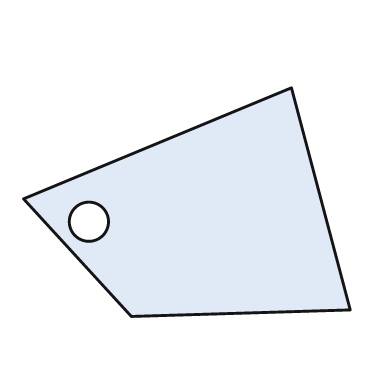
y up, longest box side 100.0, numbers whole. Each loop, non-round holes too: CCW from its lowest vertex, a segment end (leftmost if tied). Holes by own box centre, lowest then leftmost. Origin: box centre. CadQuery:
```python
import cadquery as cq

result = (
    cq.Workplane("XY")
    .moveTo(-17.0, -35.0)
    .lineTo(50.0, -33.0)
    .lineTo(32.0, 35.0)
    .lineTo(-50.0, 1.0)
    .close()
    .moveTo(-30.0, -6.0)
    .circle(6.0)
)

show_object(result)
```